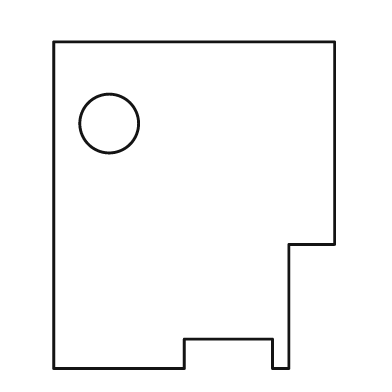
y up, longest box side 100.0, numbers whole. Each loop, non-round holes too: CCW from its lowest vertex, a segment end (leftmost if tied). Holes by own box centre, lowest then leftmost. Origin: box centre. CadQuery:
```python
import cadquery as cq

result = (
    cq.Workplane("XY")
    .moveTo(-43.0, -50.0)
    .lineTo(-3.0, -50.0)
    .lineTo(-3.0, -41.0)
    .lineTo(24.0, -41.0)
    .lineTo(24.0, -50.0)
    .lineTo(29.0, -50.0)
    .lineTo(29.0, -12.0)
    .lineTo(43.0, -12.0)
    .lineTo(43.0, 50.0)
    .lineTo(-43.0, 50.0)
    .close()
    .moveTo(-26.0, 25.0)
    .circle(9.0)
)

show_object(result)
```